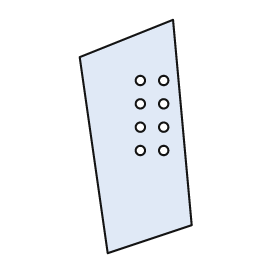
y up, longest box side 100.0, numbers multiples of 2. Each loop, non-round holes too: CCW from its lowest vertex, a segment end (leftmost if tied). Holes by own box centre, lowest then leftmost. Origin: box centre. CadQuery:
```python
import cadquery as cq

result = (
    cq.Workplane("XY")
    .moveTo(-12.0, -50.0)
    .lineTo(24.0, -38.0)
    .lineTo(16.0, 50.0)
    .lineTo(-24.0, 34.0)
    .close()
    .moveTo(2.0, -6.0)
    .circle(2.0)
    .moveTo(12.0, -6.0)
    .circle(2.0)
    .moveTo(2.0, 4.0)
    .circle(2.0)
    .moveTo(12.0, 4.0)
    .circle(2.0)
    .moveTo(2.0, 14.0)
    .circle(2.0)
    .moveTo(12.0, 14.0)
    .circle(2.0)
    .moveTo(2.0, 24.0)
    .circle(2.0)
    .moveTo(12.0, 24.0)
    .circle(2.0)
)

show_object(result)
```